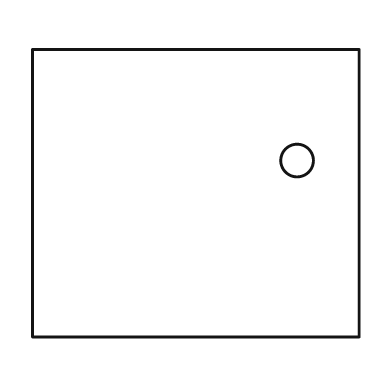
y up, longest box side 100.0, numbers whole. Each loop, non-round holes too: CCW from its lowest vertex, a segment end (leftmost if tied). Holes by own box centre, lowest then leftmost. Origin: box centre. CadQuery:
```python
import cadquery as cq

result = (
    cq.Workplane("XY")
    .moveTo(-50.0, -44.0)
    .lineTo(50.0, -44.0)
    .lineTo(50.0, 44.0)
    .lineTo(-50.0, 44.0)
    .close()
    .moveTo(31.0, 10.0)
    .circle(5.0)
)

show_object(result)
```